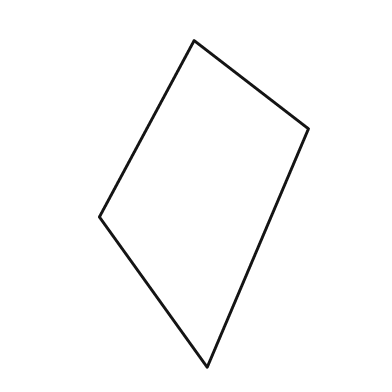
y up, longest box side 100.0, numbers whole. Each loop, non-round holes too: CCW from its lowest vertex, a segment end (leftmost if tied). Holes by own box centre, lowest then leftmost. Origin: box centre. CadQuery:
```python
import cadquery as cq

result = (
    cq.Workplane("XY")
    .moveTo(1.0, -50.0)
    .lineTo(32.0, 23.0)
    .lineTo(-3.0, 50.0)
    .lineTo(-32.0, -4.0)
    .close()
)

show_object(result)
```